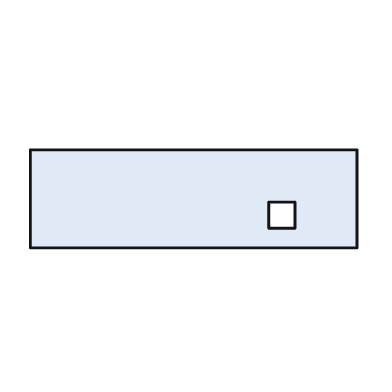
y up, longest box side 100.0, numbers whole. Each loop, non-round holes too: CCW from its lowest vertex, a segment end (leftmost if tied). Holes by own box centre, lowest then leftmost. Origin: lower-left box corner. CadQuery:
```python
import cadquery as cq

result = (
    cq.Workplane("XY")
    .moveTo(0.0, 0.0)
    .lineTo(100.0, 0.0)
    .lineTo(100.0, 30.0)
    .lineTo(0.0, 30.0)
    .close()
    .moveTo(73.0, 6.0)
    .lineTo(81.0, 6.0)
    .lineTo(81.0, 14.0)
    .lineTo(73.0, 14.0)
    .close()
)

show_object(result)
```